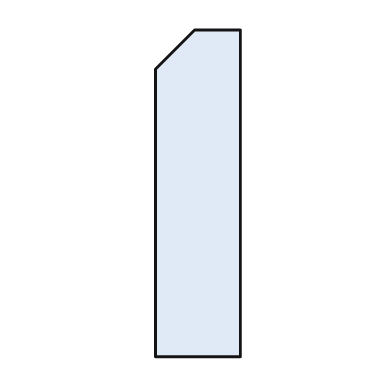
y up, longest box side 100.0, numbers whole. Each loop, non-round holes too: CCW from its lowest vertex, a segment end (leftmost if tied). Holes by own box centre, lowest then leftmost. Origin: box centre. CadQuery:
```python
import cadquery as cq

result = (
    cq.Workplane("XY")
    .moveTo(-13.0, -50.0)
    .lineTo(13.0, -50.0)
    .lineTo(13.0, 50.0)
    .lineTo(-1.0, 50.0)
    .lineTo(-13.0, 38.0)
    .close()
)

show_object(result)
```